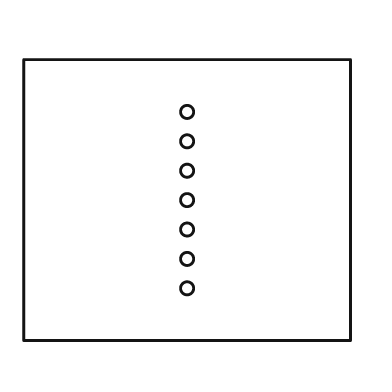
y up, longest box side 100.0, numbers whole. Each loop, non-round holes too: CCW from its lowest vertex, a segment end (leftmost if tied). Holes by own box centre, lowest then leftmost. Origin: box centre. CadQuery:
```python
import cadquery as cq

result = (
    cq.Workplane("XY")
    .moveTo(-50.0, -43.0)
    .lineTo(50.0, -43.0)
    .lineTo(50.0, 43.0)
    .lineTo(-50.0, 43.0)
    .close()
    .moveTo(0.0, -27.0)
    .circle(2.0)
    .moveTo(0.0, -18.0)
    .circle(2.0)
    .moveTo(0.0, -9.0)
    .circle(2.0)
    .moveTo(0.0, 0.0)
    .circle(2.0)
    .moveTo(0.0, 9.0)
    .circle(2.0)
    .moveTo(0.0, 18.0)
    .circle(2.0)
    .moveTo(0.0, 27.0)
    .circle(2.0)
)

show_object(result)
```